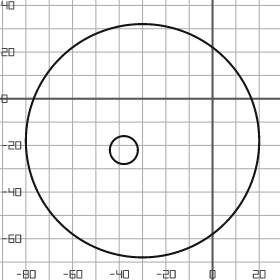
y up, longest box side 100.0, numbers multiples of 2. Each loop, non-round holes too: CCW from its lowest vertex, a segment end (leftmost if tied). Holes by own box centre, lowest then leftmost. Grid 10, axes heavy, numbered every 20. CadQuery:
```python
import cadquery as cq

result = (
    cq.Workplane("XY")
    .moveTo(-30.0, -18.0)
    .circle(50.0)
    .moveTo(-38.0, -22.0)
    .circle(6.0)
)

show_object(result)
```